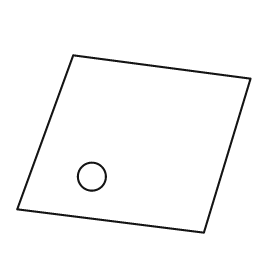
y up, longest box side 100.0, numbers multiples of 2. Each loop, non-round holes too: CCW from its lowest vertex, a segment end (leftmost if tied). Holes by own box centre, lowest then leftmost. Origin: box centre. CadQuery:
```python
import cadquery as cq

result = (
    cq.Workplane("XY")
    .moveTo(30.0, -38.0)
    .lineTo(50.0, 28.0)
    .lineTo(-26.0, 38.0)
    .lineTo(-50.0, -28.0)
    .close()
    .moveTo(-18.0, -14.0)
    .circle(6.0)
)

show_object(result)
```